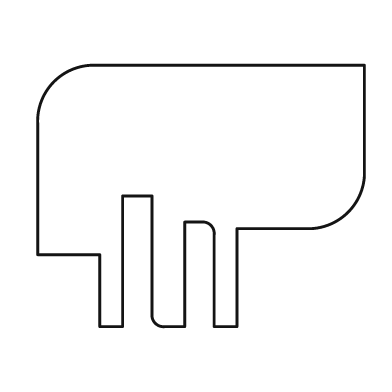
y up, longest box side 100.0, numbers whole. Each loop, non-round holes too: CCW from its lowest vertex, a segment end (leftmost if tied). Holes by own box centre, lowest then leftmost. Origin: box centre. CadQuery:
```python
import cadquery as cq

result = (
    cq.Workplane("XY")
    .moveTo(-31.0, -40.0)
    .lineTo(-24.0, -40.0)
    .lineTo(-24.0, 0.0)
    .lineTo(-15.0, 0.0)
    .lineTo(-15.0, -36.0)
    .threePointArc((-14.0, -39.0), (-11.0, -40.0))
    .lineTo(-5.0, -40.0)
    .lineTo(-5.0, -8.0)
    .lineTo(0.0, -8.0)
    .threePointArc((3.0, -9.0), (4.0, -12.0))
    .lineTo(4.0, -40.0)
    .lineTo(11.0, -40.0)
    .lineTo(11.0, -10.0)
    .lineTo(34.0, -10.0)
    .threePointArc((45.0, -5.0), (50.0, 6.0))
    .lineTo(50.0, 40.0)
    .lineTo(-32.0, 40.0)
    .threePointArc((-45.0, 35.0), (-50.0, 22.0))
    .lineTo(-50.0, -18.0)
    .lineTo(-31.0, -18.0)
    .close()
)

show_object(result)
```